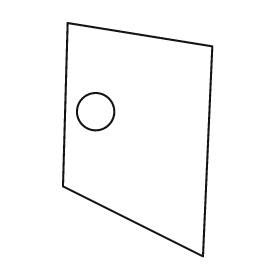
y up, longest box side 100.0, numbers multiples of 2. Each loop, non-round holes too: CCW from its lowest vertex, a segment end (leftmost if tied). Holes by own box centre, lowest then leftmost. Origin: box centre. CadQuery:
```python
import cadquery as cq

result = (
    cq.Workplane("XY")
    .moveTo(28.0, -50.0)
    .lineTo(32.0, 40.0)
    .lineTo(-30.0, 50.0)
    .lineTo(-32.0, -20.0)
    .close()
    .moveTo(-18.0, 12.0)
    .circle(8.0)
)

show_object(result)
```